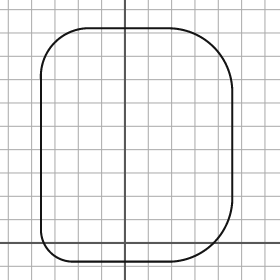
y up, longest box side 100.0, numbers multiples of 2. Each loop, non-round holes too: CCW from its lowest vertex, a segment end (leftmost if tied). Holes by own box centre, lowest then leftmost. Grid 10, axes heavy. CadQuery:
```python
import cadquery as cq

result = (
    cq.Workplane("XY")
    .moveTo(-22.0, -8.0)
    .lineTo(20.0, -8.0)
    .threePointArc((38.0, 0.0), (46.0, 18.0))
    .lineTo(46.0, 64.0)
    .threePointArc((38.0, 84.0), (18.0, 92.0))
    .lineTo(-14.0, 92.0)
    .threePointArc((-30.0, 86.0), (-36.0, 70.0))
    .lineTo(-36.0, 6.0)
    .threePointArc((-32.0, -4.0), (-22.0, -8.0))
    .close()
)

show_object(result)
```